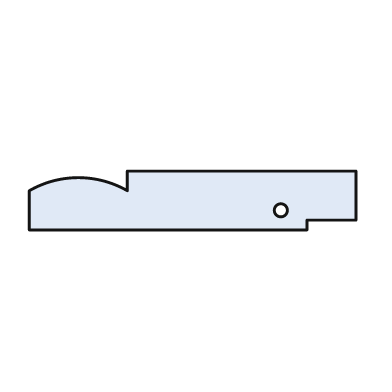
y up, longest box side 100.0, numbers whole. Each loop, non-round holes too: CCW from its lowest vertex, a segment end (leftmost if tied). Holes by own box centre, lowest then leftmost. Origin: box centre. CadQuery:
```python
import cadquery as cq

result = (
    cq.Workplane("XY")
    .moveTo(-50.0, -9.0)
    .lineTo(35.0, -9.0)
    .lineTo(35.0, -6.0)
    .lineTo(50.0, -6.0)
    .lineTo(50.0, 9.0)
    .lineTo(-20.0, 9.0)
    .lineTo(-20.0, 3.0)
    .threePointArc((-35.0, 7.0), (-50.0, 3.0))
    .close()
    .moveTo(27.0, -3.0)
    .circle(2.0)
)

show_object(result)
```